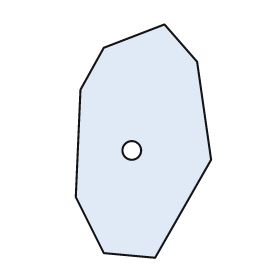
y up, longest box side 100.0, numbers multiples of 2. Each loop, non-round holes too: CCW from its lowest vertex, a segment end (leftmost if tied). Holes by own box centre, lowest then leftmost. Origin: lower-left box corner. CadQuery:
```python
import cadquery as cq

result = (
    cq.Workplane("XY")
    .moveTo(34.0, 0.0)
    .lineTo(58.0, 42.0)
    .lineTo(52.0, 84.0)
    .lineTo(38.0, 100.0)
    .lineTo(12.0, 90.0)
    .lineTo(2.0, 72.0)
    .lineTo(0.0, 26.0)
    .lineTo(12.0, 2.0)
    .close()
    .moveTo(24.0, 46.0)
    .circle(4.0)
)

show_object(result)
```